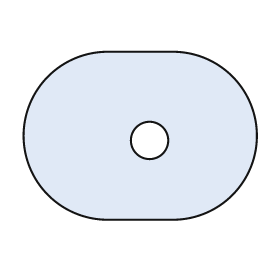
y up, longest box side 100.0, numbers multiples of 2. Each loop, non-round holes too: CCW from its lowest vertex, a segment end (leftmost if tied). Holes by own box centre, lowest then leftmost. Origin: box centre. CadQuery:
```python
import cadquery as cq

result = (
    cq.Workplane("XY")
    .moveTo(-14.0, -36.0)
    .lineTo(14.0, -36.0)
    .threePointArc((50.0, 0.0), (14.0, 36.0))
    .lineTo(-14.0, 36.0)
    .threePointArc((-50.0, 0.0), (-14.0, -36.0))
    .close()
    .moveTo(4.0, -2.0)
    .circle(8.0)
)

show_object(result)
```